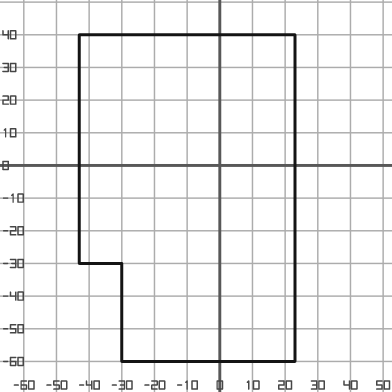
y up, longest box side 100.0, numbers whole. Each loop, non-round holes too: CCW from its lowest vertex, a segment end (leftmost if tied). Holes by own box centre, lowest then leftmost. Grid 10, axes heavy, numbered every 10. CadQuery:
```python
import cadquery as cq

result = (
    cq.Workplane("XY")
    .moveTo(-30.0, -60.0)
    .lineTo(23.0, -60.0)
    .lineTo(23.0, 40.0)
    .lineTo(-43.0, 40.0)
    .lineTo(-43.0, -30.0)
    .lineTo(-30.0, -30.0)
    .close()
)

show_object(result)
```